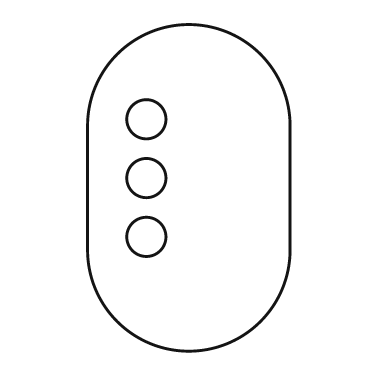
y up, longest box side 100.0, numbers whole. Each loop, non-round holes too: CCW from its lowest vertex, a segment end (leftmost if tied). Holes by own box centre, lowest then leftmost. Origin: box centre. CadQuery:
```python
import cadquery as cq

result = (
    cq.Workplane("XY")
    .moveTo(-31.0, -19.0)
    .threePointArc((0.0, -50.0), (31.0, -19.0))
    .lineTo(31.0, 19.0)
    .threePointArc((0.0, 50.0), (-31.0, 19.0))
    .close()
    .moveTo(-13.0, -15.0)
    .circle(6.0)
    .moveTo(-13.0, 3.0)
    .circle(6.0)
    .moveTo(-13.0, 21.0)
    .circle(6.0)
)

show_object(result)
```